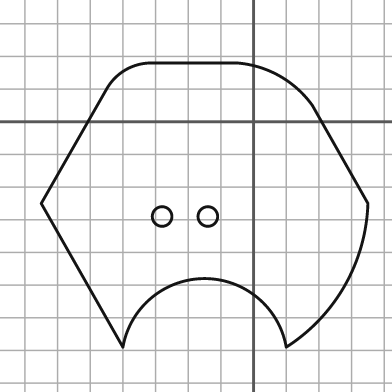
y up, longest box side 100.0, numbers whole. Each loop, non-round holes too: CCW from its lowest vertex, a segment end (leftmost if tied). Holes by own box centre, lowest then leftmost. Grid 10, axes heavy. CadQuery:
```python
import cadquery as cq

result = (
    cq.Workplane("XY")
    .moveTo(-40.0, -69.0)
    .threePointArc((-15.0, -48.0), (10.0, -69.0))
    .threePointArc((28.0, -50.0), (35.0, -25.0))
    .lineTo(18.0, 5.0)
    .threePointArc((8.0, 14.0), (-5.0, 18.0))
    .lineTo(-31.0, 18.0)
    .threePointArc((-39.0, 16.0), (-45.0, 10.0))
    .lineTo(-65.0, -25.0)
    .close()
    .moveTo(-28.0, -29.0)
    .circle(3.0)
    .moveTo(-14.0, -29.0)
    .circle(3.0)
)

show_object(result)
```